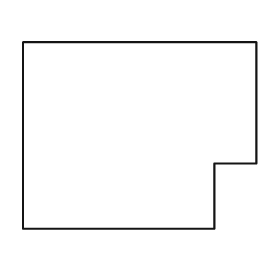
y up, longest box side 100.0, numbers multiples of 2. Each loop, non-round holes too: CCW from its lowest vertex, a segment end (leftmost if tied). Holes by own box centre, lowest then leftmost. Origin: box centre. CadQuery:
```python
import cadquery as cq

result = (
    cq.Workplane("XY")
    .moveTo(-50.0, -40.0)
    .lineTo(32.0, -40.0)
    .lineTo(32.0, -12.0)
    .lineTo(50.0, -12.0)
    .lineTo(50.0, 40.0)
    .lineTo(-50.0, 40.0)
    .close()
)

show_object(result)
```